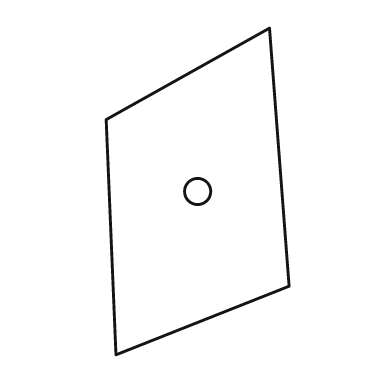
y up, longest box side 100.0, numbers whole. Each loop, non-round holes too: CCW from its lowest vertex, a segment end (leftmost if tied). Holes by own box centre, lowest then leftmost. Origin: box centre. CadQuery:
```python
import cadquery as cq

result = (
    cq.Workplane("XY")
    .moveTo(-25.0, -50.0)
    .lineTo(28.0, -29.0)
    .lineTo(22.0, 50.0)
    .lineTo(-28.0, 22.0)
    .close()
    .moveTo(0.0, 0.0)
    .circle(4.0)
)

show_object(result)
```